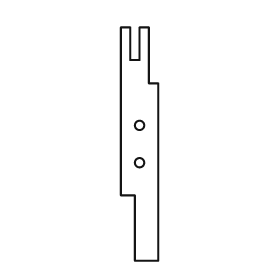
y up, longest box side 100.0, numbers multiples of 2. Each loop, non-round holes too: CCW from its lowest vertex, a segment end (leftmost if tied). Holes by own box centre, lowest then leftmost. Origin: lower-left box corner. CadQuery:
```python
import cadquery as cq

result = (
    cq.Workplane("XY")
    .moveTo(6.0, 0.0)
    .lineTo(16.0, 0.0)
    .lineTo(16.0, 76.0)
    .lineTo(12.0, 76.0)
    .lineTo(12.0, 100.0)
    .lineTo(8.0, 100.0)
    .lineTo(8.0, 86.0)
    .lineTo(4.0, 86.0)
    .lineTo(4.0, 100.0)
    .lineTo(0.0, 100.0)
    .lineTo(0.0, 28.0)
    .lineTo(6.0, 28.0)
    .close()
    .moveTo(8.0, 42.0)
    .circle(2.0)
    .moveTo(8.0, 58.0)
    .circle(2.0)
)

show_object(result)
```